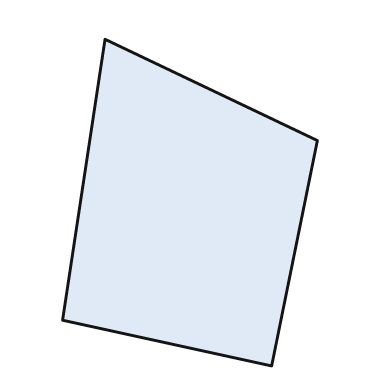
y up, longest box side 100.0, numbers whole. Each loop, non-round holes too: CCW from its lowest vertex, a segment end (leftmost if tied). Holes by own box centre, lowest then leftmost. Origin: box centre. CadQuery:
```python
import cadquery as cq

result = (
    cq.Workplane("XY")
    .moveTo(25.0, -50.0)
    .lineTo(39.0, 19.0)
    .lineTo(-26.0, 50.0)
    .lineTo(-39.0, -36.0)
    .close()
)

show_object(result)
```